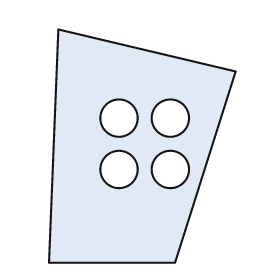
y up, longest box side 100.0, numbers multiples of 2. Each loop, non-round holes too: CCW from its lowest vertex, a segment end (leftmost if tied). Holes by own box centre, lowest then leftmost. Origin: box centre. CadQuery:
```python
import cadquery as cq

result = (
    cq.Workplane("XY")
    .moveTo(-40.0, -50.0)
    .lineTo(14.0, -50.0)
    .lineTo(40.0, 32.0)
    .lineTo(-36.0, 50.0)
    .close()
    .moveTo(-10.0, -10.0)
    .circle(8.0)
    .moveTo(12.0, -10.0)
    .circle(8.0)
    .moveTo(-10.0, 12.0)
    .circle(8.0)
    .moveTo(12.0, 12.0)
    .circle(8.0)
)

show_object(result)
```